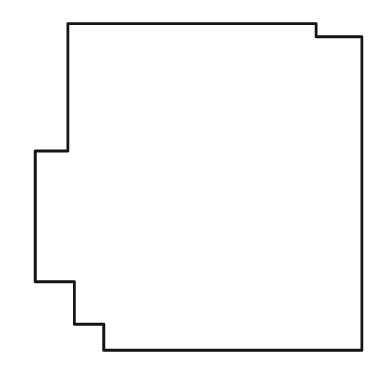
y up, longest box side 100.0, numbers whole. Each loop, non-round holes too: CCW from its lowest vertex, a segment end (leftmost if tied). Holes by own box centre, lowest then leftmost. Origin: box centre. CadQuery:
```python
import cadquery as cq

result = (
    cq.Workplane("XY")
    .moveTo(-29.0, -50.0)
    .lineTo(50.0, -50.0)
    .lineTo(50.0, 46.0)
    .lineTo(36.0, 46.0)
    .lineTo(36.0, 50.0)
    .lineTo(-40.0, 50.0)
    .lineTo(-40.0, 11.0)
    .lineTo(-50.0, 11.0)
    .lineTo(-50.0, -29.0)
    .lineTo(-38.0, -29.0)
    .lineTo(-38.0, -42.0)
    .lineTo(-29.0, -42.0)
    .close()
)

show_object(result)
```